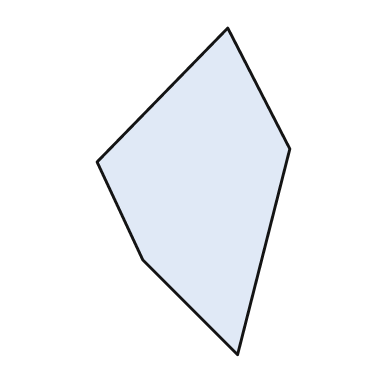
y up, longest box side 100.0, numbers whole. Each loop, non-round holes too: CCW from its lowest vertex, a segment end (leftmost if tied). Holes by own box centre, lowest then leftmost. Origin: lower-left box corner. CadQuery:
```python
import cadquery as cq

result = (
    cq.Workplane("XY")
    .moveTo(43.0, 0.0)
    .lineTo(59.0, 63.0)
    .lineTo(40.0, 100.0)
    .lineTo(0.0, 59.0)
    .lineTo(14.0, 29.0)
    .close()
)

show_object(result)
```